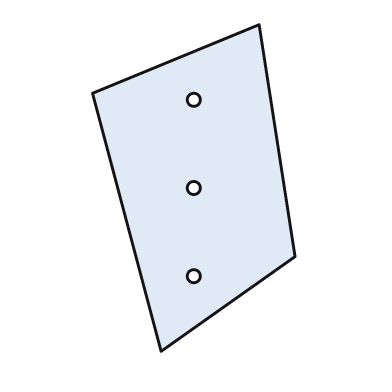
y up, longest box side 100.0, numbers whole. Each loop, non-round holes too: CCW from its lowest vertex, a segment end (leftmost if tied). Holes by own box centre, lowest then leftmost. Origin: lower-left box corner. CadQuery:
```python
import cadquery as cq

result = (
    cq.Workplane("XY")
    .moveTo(21.0, 0.0)
    .lineTo(62.0, 29.0)
    .lineTo(51.0, 100.0)
    .lineTo(0.0, 79.0)
    .close()
    .moveTo(31.0, 23.0)
    .circle(2.0)
    .moveTo(31.0, 50.0)
    .circle(2.0)
    .moveTo(31.0, 77.0)
    .circle(2.0)
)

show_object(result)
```